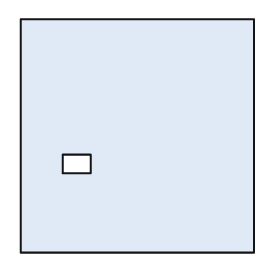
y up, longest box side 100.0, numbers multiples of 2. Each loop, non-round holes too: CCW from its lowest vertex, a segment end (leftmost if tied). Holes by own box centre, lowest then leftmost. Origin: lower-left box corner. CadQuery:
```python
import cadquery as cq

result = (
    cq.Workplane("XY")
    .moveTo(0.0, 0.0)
    .lineTo(100.0, 0.0)
    .lineTo(100.0, 100.0)
    .lineTo(0.0, 100.0)
    .close()
    .moveTo(18.0, 34.0)
    .lineTo(30.0, 34.0)
    .lineTo(30.0, 42.0)
    .lineTo(18.0, 42.0)
    .close()
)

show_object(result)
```